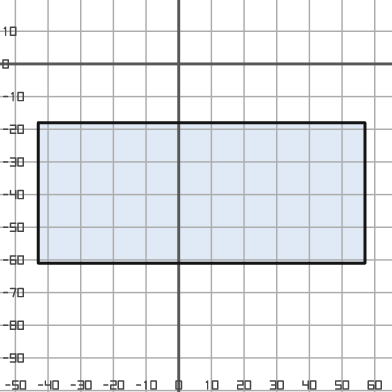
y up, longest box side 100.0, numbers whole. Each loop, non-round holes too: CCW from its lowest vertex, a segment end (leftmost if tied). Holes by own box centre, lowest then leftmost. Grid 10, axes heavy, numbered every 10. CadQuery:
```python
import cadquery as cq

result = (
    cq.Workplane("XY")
    .moveTo(-43.0, -61.0)
    .lineTo(57.0, -61.0)
    .lineTo(57.0, -18.0)
    .lineTo(-43.0, -18.0)
    .close()
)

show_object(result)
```